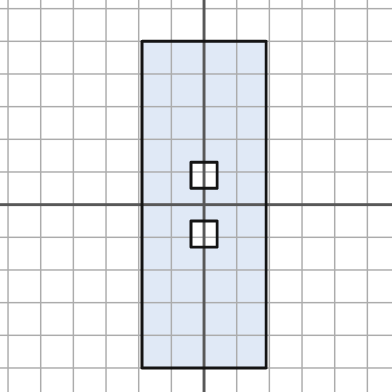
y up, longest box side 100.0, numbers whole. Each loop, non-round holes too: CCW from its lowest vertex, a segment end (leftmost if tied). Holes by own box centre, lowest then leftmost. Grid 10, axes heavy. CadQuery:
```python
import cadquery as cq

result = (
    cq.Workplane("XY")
    .moveTo(-19.0, -50.0)
    .lineTo(19.0, -50.0)
    .lineTo(19.0, 50.0)
    .lineTo(-19.0, 50.0)
    .close()
    .moveTo(-4.0, -13.0)
    .lineTo(4.0, -13.0)
    .lineTo(4.0, -5.0)
    .lineTo(-4.0, -5.0)
    .close()
    .moveTo(-4.0, 5.0)
    .lineTo(4.0, 5.0)
    .lineTo(4.0, 13.0)
    .lineTo(-4.0, 13.0)
    .close()
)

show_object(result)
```